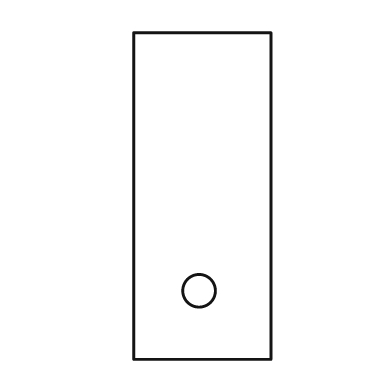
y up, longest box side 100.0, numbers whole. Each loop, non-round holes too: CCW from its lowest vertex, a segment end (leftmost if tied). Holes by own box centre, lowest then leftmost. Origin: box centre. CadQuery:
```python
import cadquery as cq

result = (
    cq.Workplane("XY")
    .moveTo(-21.0, -50.0)
    .lineTo(21.0, -50.0)
    .lineTo(21.0, 50.0)
    .lineTo(-21.0, 50.0)
    .close()
    .moveTo(-1.0, -29.0)
    .circle(5.0)
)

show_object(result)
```